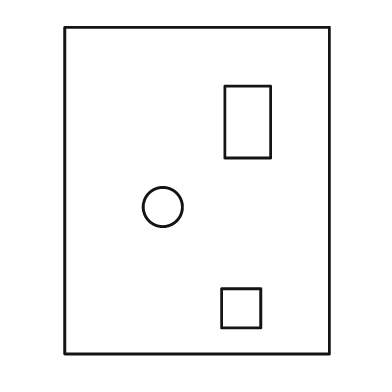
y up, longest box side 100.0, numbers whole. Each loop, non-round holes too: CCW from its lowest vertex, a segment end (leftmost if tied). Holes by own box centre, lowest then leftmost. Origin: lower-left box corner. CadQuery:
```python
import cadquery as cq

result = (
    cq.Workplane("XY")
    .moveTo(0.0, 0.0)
    .lineTo(81.0, 0.0)
    .lineTo(81.0, 100.0)
    .lineTo(0.0, 100.0)
    .close()
    .moveTo(48.0, 8.0)
    .lineTo(60.0, 8.0)
    .lineTo(60.0, 20.0)
    .lineTo(48.0, 20.0)
    .close()
    .moveTo(30.0, 45.0)
    .circle(6.0)
    .moveTo(49.0, 60.0)
    .lineTo(63.0, 60.0)
    .lineTo(63.0, 82.0)
    .lineTo(49.0, 82.0)
    .close()
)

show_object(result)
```